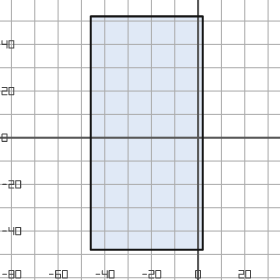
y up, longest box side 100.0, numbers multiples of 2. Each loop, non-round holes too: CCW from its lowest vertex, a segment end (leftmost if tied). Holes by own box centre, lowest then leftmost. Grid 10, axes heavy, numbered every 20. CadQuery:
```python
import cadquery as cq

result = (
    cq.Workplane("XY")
    .moveTo(-46.0, -48.0)
    .lineTo(2.0, -48.0)
    .lineTo(2.0, 52.0)
    .lineTo(-46.0, 52.0)
    .close()
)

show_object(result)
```